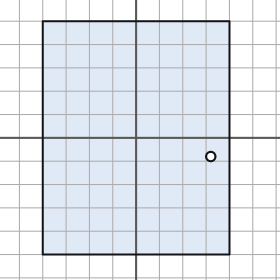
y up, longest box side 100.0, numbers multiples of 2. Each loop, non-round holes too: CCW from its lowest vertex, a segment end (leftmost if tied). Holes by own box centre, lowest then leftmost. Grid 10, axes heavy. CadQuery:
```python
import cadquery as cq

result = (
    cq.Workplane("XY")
    .moveTo(-40.0, -50.0)
    .lineTo(40.0, -50.0)
    .lineTo(40.0, 50.0)
    .lineTo(-40.0, 50.0)
    .close()
    .moveTo(32.0, -8.0)
    .circle(2.0)
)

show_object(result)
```